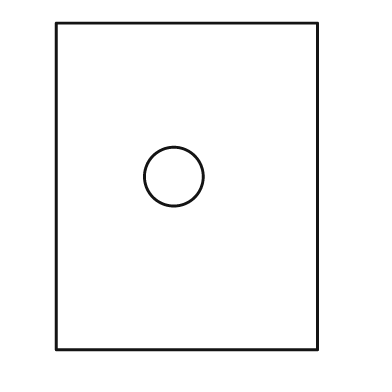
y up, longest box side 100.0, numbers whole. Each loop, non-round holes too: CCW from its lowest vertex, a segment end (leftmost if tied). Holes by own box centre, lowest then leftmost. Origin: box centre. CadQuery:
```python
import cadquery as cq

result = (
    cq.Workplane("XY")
    .moveTo(-40.0, -50.0)
    .lineTo(40.0, -50.0)
    .lineTo(40.0, 50.0)
    .lineTo(-40.0, 50.0)
    .close()
    .moveTo(-4.0, 3.0)
    .circle(9.0)
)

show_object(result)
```